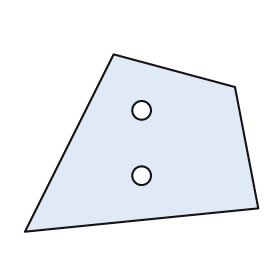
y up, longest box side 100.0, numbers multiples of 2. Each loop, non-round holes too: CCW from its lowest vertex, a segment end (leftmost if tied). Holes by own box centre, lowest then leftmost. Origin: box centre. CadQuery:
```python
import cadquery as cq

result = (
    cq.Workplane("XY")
    .moveTo(-50.0, -38.0)
    .lineTo(50.0, -28.0)
    .lineTo(40.0, 24.0)
    .lineTo(-12.0, 38.0)
    .close()
    .moveTo(0.0, -14.0)
    .circle(4.0)
    .moveTo(0.0, 14.0)
    .circle(4.0)
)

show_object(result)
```